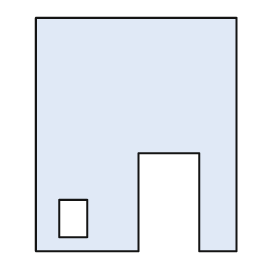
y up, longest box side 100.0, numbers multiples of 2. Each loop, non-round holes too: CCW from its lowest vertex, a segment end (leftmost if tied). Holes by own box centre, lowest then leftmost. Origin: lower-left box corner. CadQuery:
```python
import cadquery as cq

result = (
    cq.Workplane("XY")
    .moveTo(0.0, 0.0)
    .lineTo(44.0, 0.0)
    .lineTo(44.0, 42.0)
    .lineTo(70.0, 42.0)
    .lineTo(70.0, 0.0)
    .lineTo(86.0, 0.0)
    .lineTo(86.0, 100.0)
    .lineTo(0.0, 100.0)
    .close()
    .moveTo(10.0, 6.0)
    .lineTo(22.0, 6.0)
    .lineTo(22.0, 22.0)
    .lineTo(10.0, 22.0)
    .close()
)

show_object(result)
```